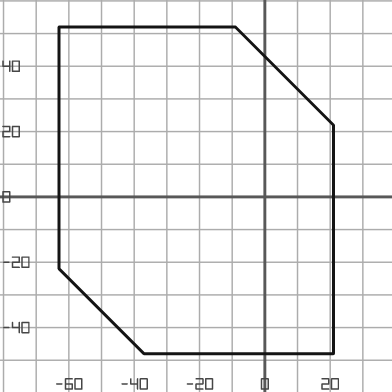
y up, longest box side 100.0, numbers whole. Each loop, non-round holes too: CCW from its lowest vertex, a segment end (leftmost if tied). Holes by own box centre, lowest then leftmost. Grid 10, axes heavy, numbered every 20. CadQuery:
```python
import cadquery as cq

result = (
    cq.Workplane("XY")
    .moveTo(-37.0, -48.0)
    .lineTo(21.0, -48.0)
    .lineTo(21.0, 22.0)
    .lineTo(-9.0, 52.0)
    .lineTo(-63.0, 52.0)
    .lineTo(-63.0, -22.0)
    .close()
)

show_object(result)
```